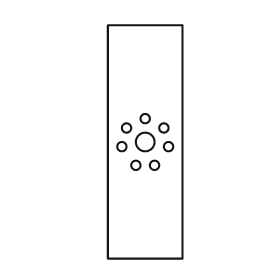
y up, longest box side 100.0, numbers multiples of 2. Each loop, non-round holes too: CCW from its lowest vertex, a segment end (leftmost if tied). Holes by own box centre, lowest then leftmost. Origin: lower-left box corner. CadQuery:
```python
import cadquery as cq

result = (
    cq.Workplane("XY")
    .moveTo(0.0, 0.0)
    .lineTo(32.0, 0.0)
    .lineTo(32.0, 100.0)
    .lineTo(0.0, 100.0)
    .close()
    .moveTo(12.0, 40.0)
    .circle(2.0)
    .moveTo(20.0, 40.0)
    .circle(2.0)
    .moveTo(6.0, 48.0)
    .circle(2.0)
    .moveTo(26.0, 48.0)
    .circle(2.0)
    .moveTo(16.0, 50.0)
    .circle(4.0)
    .moveTo(8.0, 56.0)
    .circle(2.0)
    .moveTo(24.0, 56.0)
    .circle(2.0)
    .moveTo(16.0, 60.0)
    .circle(2.0)
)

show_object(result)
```